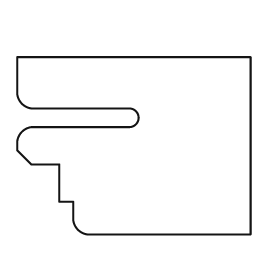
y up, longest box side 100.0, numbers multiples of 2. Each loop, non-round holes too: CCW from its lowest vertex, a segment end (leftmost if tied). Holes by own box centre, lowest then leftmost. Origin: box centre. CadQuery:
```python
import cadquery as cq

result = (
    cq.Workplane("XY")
    .moveTo(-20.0, -38.0)
    .lineTo(50.0, -38.0)
    .lineTo(50.0, 38.0)
    .lineTo(-50.0, 38.0)
    .lineTo(-50.0, 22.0)
    .threePointArc((-48.0, 18.0), (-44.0, 16.0))
    .lineTo(-2.0, 16.0)
    .threePointArc((2.0, 12.0), (-2.0, 8.0))
    .lineTo(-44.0, 8.0)
    .threePointArc((-48.0, 6.0), (-50.0, 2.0))
    .lineTo(-50.0, -2.0)
    .lineTo(-44.0, -8.0)
    .lineTo(-32.0, -8.0)
    .lineTo(-32.0, -24.0)
    .lineTo(-26.0, -24.0)
    .lineTo(-26.0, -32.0)
    .threePointArc((-24.0, -36.0), (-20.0, -38.0))
    .close()
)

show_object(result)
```